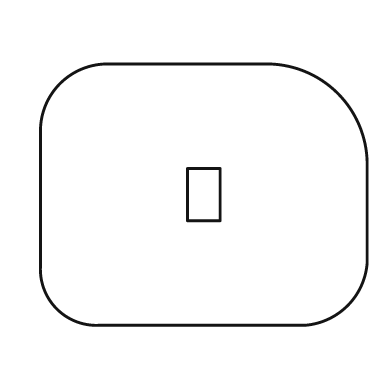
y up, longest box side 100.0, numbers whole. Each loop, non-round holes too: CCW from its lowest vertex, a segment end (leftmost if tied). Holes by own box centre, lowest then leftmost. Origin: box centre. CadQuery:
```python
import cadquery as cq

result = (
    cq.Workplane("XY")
    .moveTo(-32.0, -40.0)
    .lineTo(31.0, -40.0)
    .threePointArc((44.0, -34.0), (50.0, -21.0))
    .lineTo(50.0, 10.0)
    .threePointArc((41.0, 31.0), (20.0, 40.0))
    .lineTo(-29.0, 40.0)
    .threePointArc((-44.0, 34.0), (-50.0, 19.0))
    .lineTo(-50.0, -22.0)
    .threePointArc((-45.0, -35.0), (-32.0, -40.0))
    .close()
    .moveTo(-5.0, -8.0)
    .lineTo(5.0, -8.0)
    .lineTo(5.0, 8.0)
    .lineTo(-5.0, 8.0)
    .close()
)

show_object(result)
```